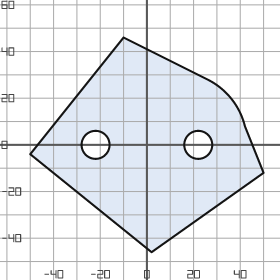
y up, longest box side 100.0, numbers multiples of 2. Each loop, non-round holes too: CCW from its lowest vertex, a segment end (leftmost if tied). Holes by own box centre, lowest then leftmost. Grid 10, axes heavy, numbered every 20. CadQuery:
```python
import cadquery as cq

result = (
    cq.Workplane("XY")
    .moveTo(2.0, -46.0)
    .lineTo(50.0, -12.0)
    .lineTo(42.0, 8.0)
    .threePointArc((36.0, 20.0), (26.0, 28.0))
    .lineTo(-10.0, 46.0)
    .lineTo(-50.0, -4.0)
    .close()
    .moveTo(-22.0, 0.0)
    .circle(6.0)
    .moveTo(22.0, 0.0)
    .circle(6.0)
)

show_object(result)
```